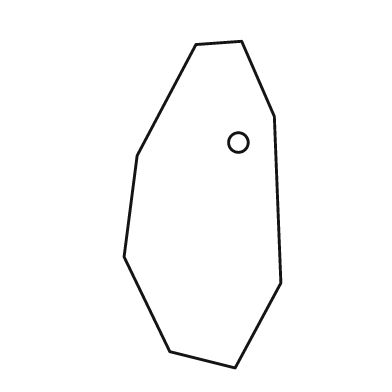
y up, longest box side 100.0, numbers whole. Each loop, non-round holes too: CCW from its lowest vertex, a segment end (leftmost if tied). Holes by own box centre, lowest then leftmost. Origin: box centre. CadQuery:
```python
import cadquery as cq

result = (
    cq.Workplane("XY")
    .moveTo(10.0, -50.0)
    .lineTo(24.0, -24.0)
    .lineTo(22.0, 27.0)
    .lineTo(12.0, 50.0)
    .lineTo(-2.0, 49.0)
    .lineTo(-20.0, 15.0)
    .lineTo(-24.0, -16.0)
    .lineTo(-10.0, -45.0)
    .close()
    .moveTo(11.0, 19.0)
    .circle(3.0)
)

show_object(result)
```